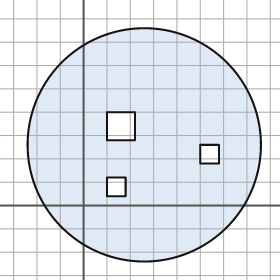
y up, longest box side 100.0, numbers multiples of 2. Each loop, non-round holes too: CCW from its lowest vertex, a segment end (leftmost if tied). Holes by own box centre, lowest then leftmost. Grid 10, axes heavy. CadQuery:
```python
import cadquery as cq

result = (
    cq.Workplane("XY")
    .moveTo(26.0, 26.0)
    .circle(50.0)
    .moveTo(10.0, 4.0)
    .lineTo(18.0, 4.0)
    .lineTo(18.0, 12.0)
    .lineTo(10.0, 12.0)
    .close()
    .moveTo(50.0, 18.0)
    .lineTo(58.0, 18.0)
    .lineTo(58.0, 26.0)
    .lineTo(50.0, 26.0)
    .close()
    .moveTo(10.0, 28.0)
    .lineTo(22.0, 28.0)
    .lineTo(22.0, 40.0)
    .lineTo(10.0, 40.0)
    .close()
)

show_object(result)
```